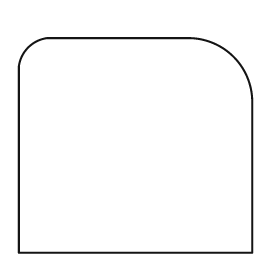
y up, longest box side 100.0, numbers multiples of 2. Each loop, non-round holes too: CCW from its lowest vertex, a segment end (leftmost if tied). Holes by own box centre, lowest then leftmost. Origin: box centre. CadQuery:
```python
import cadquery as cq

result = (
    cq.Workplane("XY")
    .moveTo(-50.0, -46.0)
    .lineTo(50.0, -46.0)
    .lineTo(50.0, 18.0)
    .threePointArc((42.0, 38.0), (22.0, 46.0))
    .lineTo(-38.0, 46.0)
    .threePointArc((-46.0, 42.0), (-50.0, 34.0))
    .close()
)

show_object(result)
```